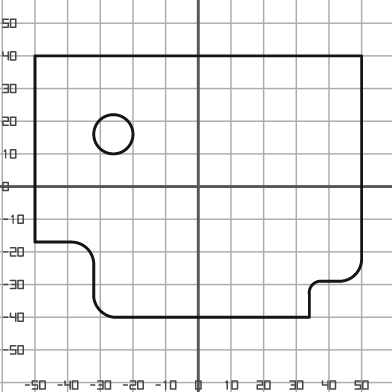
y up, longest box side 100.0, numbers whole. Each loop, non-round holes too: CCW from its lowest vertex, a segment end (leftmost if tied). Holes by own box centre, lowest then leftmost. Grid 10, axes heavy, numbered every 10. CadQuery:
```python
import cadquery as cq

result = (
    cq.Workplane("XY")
    .moveTo(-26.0, -40.0)
    .lineTo(34.0, -40.0)
    .lineTo(34.0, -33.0)
    .threePointArc((35.0, -30.0), (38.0, -29.0))
    .lineTo(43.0, -29.0)
    .threePointArc((48.0, -27.0), (50.0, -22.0))
    .lineTo(50.0, 40.0)
    .lineTo(-50.0, 40.0)
    .lineTo(-50.0, -17.0)
    .lineTo(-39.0, -17.0)
    .threePointArc((-34.0, -19.0), (-32.0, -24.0))
    .lineTo(-32.0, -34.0)
    .threePointArc((-30.0, -38.0), (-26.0, -40.0))
    .close()
    .moveTo(-26.0, 16.0)
    .circle(6.0)
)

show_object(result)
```